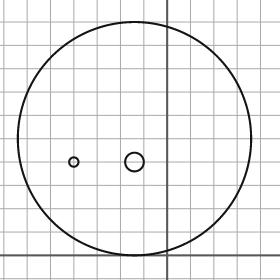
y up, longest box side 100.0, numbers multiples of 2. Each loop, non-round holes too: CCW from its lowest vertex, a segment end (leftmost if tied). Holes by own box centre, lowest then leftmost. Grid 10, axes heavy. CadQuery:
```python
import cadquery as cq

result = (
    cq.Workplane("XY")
    .moveTo(-14.0, 50.0)
    .circle(50.0)
    .moveTo(-40.0, 40.0)
    .circle(2.0)
    .moveTo(-14.0, 40.0)
    .circle(4.0)
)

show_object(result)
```